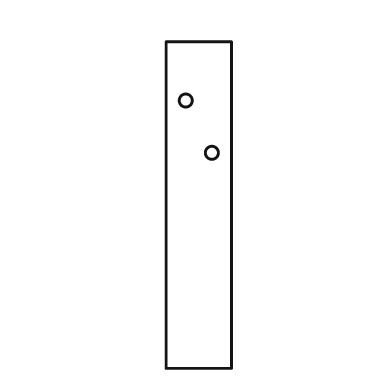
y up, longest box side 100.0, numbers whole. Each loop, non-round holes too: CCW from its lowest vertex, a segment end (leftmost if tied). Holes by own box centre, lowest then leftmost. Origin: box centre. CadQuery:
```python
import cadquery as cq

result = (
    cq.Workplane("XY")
    .moveTo(-10.0, -50.0)
    .lineTo(10.0, -50.0)
    .lineTo(10.0, 50.0)
    .lineTo(-10.0, 50.0)
    .close()
    .moveTo(4.0, 16.0)
    .circle(2.0)
    .moveTo(-4.0, 32.0)
    .circle(2.0)
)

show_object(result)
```